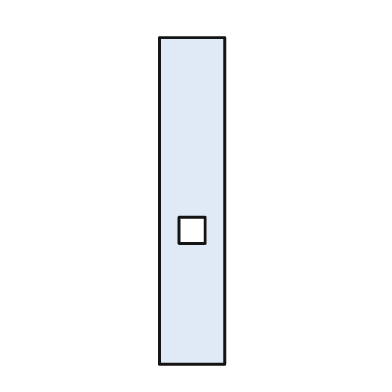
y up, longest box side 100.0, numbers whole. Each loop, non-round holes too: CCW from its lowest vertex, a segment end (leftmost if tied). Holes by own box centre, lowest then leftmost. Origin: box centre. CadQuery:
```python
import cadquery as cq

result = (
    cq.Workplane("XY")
    .moveTo(-10.0, -50.0)
    .lineTo(10.0, -50.0)
    .lineTo(10.0, 50.0)
    .lineTo(-10.0, 50.0)
    .close()
    .moveTo(-4.0, -13.0)
    .lineTo(4.0, -13.0)
    .lineTo(4.0, -5.0)
    .lineTo(-4.0, -5.0)
    .close()
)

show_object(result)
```